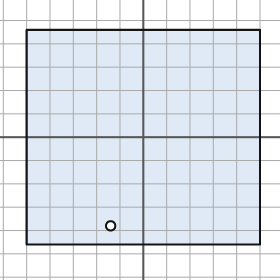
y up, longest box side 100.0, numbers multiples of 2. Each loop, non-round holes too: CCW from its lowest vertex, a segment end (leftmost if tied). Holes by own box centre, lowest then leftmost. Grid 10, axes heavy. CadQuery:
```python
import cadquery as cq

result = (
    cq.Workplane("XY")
    .moveTo(-50.0, -46.0)
    .lineTo(50.0, -46.0)
    .lineTo(50.0, 46.0)
    .lineTo(-50.0, 46.0)
    .close()
    .moveTo(-14.0, -38.0)
    .circle(2.0)
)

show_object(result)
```